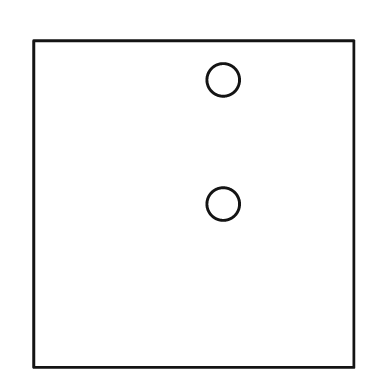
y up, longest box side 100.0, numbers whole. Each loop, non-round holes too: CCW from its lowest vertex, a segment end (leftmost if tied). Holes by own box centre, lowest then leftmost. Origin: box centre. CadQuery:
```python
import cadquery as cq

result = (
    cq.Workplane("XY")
    .moveTo(-49.0, -50.0)
    .lineTo(49.0, -50.0)
    .lineTo(49.0, 50.0)
    .lineTo(-49.0, 50.0)
    .close()
    .moveTo(9.0, 0.0)
    .circle(5.0)
    .moveTo(9.0, 38.0)
    .circle(5.0)
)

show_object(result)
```